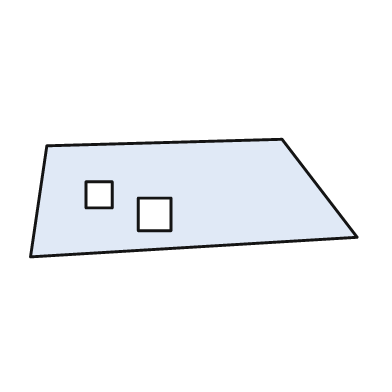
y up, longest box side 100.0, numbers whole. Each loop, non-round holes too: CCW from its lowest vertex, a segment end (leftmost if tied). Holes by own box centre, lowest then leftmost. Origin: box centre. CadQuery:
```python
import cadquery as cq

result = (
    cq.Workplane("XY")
    .moveTo(-50.0, -18.0)
    .lineTo(50.0, -12.0)
    .lineTo(27.0, 18.0)
    .lineTo(-45.0, 16.0)
    .close()
    .moveTo(-17.0, -10.0)
    .lineTo(-7.0, -10.0)
    .lineTo(-7.0, 0.0)
    .lineTo(-17.0, 0.0)
    .close()
    .moveTo(-33.0, -3.0)
    .lineTo(-25.0, -3.0)
    .lineTo(-25.0, 5.0)
    .lineTo(-33.0, 5.0)
    .close()
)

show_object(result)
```